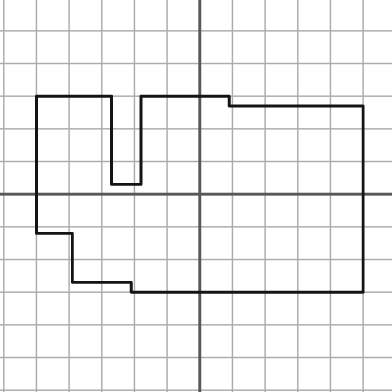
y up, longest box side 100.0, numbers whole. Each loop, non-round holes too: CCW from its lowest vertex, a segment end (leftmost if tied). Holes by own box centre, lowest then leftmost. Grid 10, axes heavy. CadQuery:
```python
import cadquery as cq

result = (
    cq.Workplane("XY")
    .moveTo(-21.0, -30.0)
    .lineTo(50.0, -30.0)
    .lineTo(50.0, 27.0)
    .lineTo(9.0, 27.0)
    .lineTo(9.0, 30.0)
    .lineTo(-18.0, 30.0)
    .lineTo(-18.0, 3.0)
    .lineTo(-27.0, 3.0)
    .lineTo(-27.0, 30.0)
    .lineTo(-50.0, 30.0)
    .lineTo(-50.0, -12.0)
    .lineTo(-39.0, -12.0)
    .lineTo(-39.0, -27.0)
    .lineTo(-21.0, -27.0)
    .close()
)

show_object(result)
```